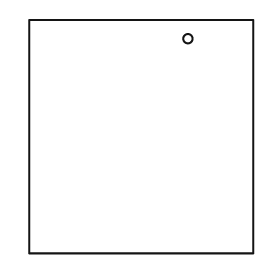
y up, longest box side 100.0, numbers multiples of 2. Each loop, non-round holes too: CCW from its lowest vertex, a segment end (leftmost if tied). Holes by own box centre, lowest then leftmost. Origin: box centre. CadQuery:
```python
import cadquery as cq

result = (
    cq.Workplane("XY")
    .moveTo(-48.0, -50.0)
    .lineTo(48.0, -50.0)
    .lineTo(48.0, 50.0)
    .lineTo(-48.0, 50.0)
    .close()
    .moveTo(20.0, 42.0)
    .circle(2.0)
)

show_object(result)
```